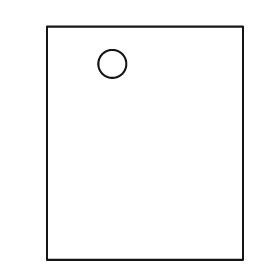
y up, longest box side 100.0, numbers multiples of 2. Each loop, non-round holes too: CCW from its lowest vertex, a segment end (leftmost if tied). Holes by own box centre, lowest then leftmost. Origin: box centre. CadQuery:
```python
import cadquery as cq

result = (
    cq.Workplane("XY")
    .moveTo(-42.0, -50.0)
    .lineTo(42.0, -50.0)
    .lineTo(42.0, 50.0)
    .lineTo(-42.0, 50.0)
    .close()
    .moveTo(-14.0, 34.0)
    .circle(6.0)
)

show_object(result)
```